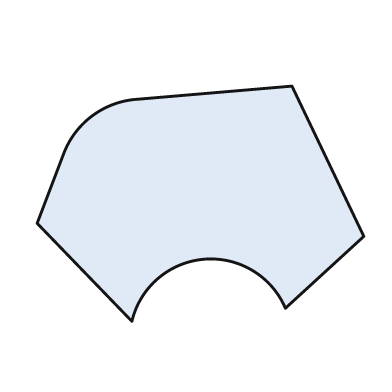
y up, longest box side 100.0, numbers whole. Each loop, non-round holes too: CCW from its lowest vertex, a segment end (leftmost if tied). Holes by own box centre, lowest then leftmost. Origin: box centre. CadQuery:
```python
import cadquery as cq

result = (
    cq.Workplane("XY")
    .moveTo(-21.0, -36.0)
    .threePointArc((1.0, -17.0), (26.0, -32.0))
    .lineTo(50.0, -10.0)
    .lineTo(28.0, 36.0)
    .lineTo(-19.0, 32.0)
    .threePointArc((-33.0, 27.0), (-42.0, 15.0))
    .lineTo(-50.0, -6.0)
    .close()
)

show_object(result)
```